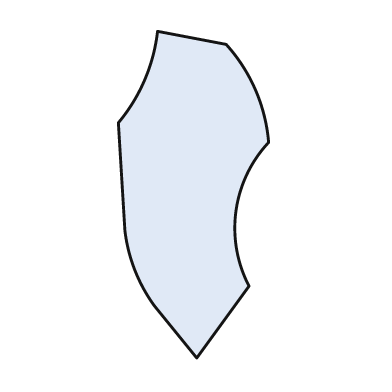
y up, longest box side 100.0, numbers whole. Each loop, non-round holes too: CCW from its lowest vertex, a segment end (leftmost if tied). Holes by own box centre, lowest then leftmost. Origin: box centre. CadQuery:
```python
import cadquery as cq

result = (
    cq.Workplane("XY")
    .moveTo(1.0, -50.0)
    .lineTo(17.0, -28.0)
    .threePointArc((13.0, -5.0), (23.0, 16.0))
    .threePointArc((19.0, 32.0), (10.0, 46.0))
    .lineTo(-11.0, 50.0)
    .threePointArc((-15.0, 35.0), (-23.0, 22.0))
    .lineTo(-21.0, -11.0)
    .threePointArc((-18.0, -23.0), (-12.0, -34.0))
    .close()
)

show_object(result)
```